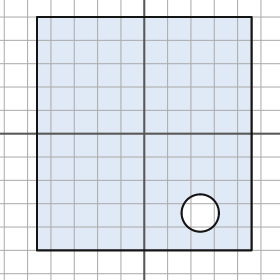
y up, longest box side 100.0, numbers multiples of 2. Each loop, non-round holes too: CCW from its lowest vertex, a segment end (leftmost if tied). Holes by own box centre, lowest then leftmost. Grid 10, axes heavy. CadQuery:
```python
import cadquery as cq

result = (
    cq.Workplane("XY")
    .moveTo(-46.0, -50.0)
    .lineTo(46.0, -50.0)
    .lineTo(46.0, 50.0)
    .lineTo(-46.0, 50.0)
    .close()
    .moveTo(24.0, -34.0)
    .circle(8.0)
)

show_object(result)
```